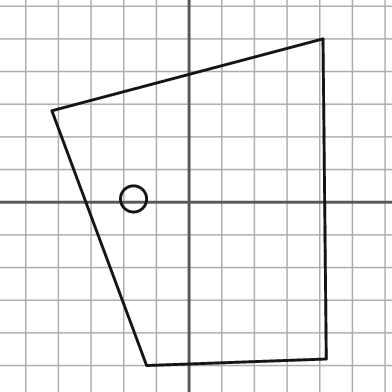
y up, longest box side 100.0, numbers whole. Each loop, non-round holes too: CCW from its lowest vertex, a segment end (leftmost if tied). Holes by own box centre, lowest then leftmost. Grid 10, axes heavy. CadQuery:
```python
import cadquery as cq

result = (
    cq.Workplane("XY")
    .moveTo(-13.0, -50.0)
    .lineTo(42.0, -48.0)
    .lineTo(41.0, 50.0)
    .lineTo(-42.0, 28.0)
    .close()
    .moveTo(-17.0, 1.0)
    .circle(4.0)
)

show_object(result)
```